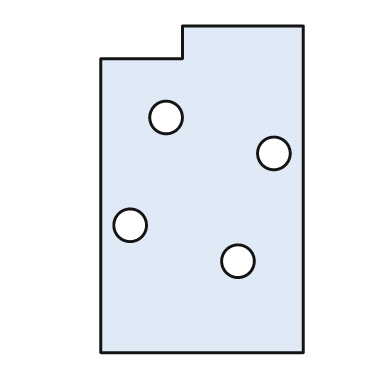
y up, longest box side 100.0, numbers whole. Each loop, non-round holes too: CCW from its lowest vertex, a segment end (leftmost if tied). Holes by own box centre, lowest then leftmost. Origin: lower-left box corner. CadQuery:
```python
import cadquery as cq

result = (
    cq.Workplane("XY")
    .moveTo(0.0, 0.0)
    .lineTo(62.0, 0.0)
    .lineTo(62.0, 100.0)
    .lineTo(25.0, 100.0)
    .lineTo(25.0, 90.0)
    .lineTo(0.0, 90.0)
    .close()
    .moveTo(42.0, 28.0)
    .circle(5.0)
    .moveTo(9.0, 39.0)
    .circle(5.0)
    .moveTo(53.0, 61.0)
    .circle(5.0)
    .moveTo(20.0, 72.0)
    .circle(5.0)
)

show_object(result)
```